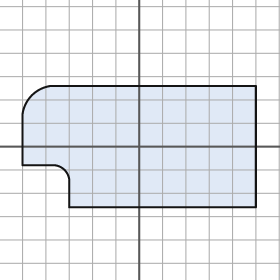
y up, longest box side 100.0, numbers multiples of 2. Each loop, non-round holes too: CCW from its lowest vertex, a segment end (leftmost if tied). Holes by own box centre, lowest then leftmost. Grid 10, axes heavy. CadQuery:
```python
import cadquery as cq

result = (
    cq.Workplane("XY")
    .moveTo(-30.0, -26.0)
    .lineTo(50.0, -26.0)
    .lineTo(50.0, 26.0)
    .lineTo(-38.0, 26.0)
    .threePointArc((-46.0, 22.0), (-50.0, 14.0))
    .lineTo(-50.0, -8.0)
    .lineTo(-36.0, -8.0)
    .threePointArc((-32.0, -10.0), (-30.0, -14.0))
    .close()
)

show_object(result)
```